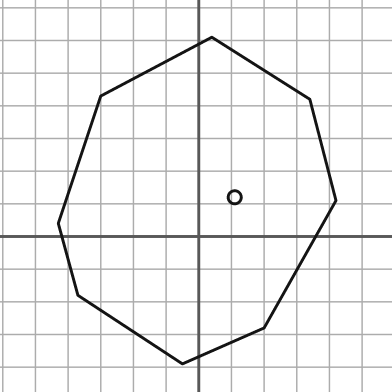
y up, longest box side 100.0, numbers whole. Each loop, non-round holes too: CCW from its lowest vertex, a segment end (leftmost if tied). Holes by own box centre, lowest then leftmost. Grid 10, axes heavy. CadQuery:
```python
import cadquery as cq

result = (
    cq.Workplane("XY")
    .moveTo(-5.0, -39.0)
    .lineTo(20.0, -28.0)
    .lineTo(42.0, 11.0)
    .lineTo(34.0, 42.0)
    .lineTo(4.0, 61.0)
    .lineTo(-30.0, 43.0)
    .lineTo(-43.0, 4.0)
    .lineTo(-37.0, -18.0)
    .close()
    .moveTo(11.0, 12.0)
    .circle(2.0)
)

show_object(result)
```